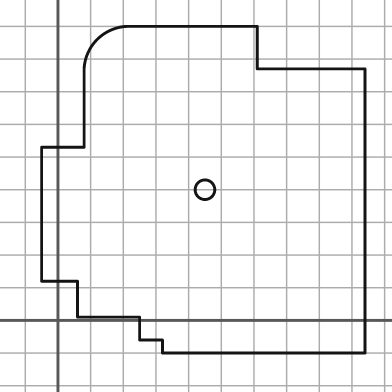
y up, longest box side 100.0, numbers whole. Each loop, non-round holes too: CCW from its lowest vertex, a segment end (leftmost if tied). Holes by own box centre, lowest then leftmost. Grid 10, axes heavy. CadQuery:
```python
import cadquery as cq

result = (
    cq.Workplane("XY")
    .moveTo(32.0, -10.0)
    .lineTo(94.0, -10.0)
    .lineTo(94.0, 77.0)
    .lineTo(61.0, 77.0)
    .lineTo(61.0, 90.0)
    .lineTo(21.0, 90.0)
    .threePointArc((12.0, 86.0), (8.0, 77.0))
    .lineTo(8.0, 53.0)
    .lineTo(-5.0, 53.0)
    .lineTo(-5.0, 12.0)
    .lineTo(6.0, 12.0)
    .lineTo(6.0, 1.0)
    .lineTo(25.0, 1.0)
    .lineTo(25.0, -6.0)
    .lineTo(32.0, -6.0)
    .close()
    .moveTo(45.0, 40.0)
    .circle(3.0)
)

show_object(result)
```